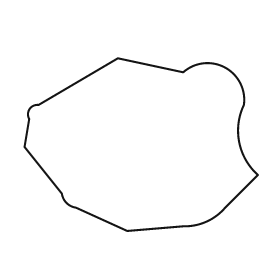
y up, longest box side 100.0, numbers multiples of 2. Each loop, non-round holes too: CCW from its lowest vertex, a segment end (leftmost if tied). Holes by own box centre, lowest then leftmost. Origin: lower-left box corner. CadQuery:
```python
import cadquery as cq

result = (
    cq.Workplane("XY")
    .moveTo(44.0, 0.0)
    .lineTo(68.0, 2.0)
    .threePointArc((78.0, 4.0), (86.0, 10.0))
    .lineTo(100.0, 24.0)
    .threePointArc((92.0, 38.0), (94.0, 54.0))
    .threePointArc((86.0, 70.0), (68.0, 68.0))
    .lineTo(40.0, 74.0)
    .lineTo(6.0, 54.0)
    .threePointArc((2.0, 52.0), (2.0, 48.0))
    .lineTo(0.0, 36.0)
    .lineTo(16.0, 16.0)
    .threePointArc((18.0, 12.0), (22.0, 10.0))
    .close()
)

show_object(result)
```